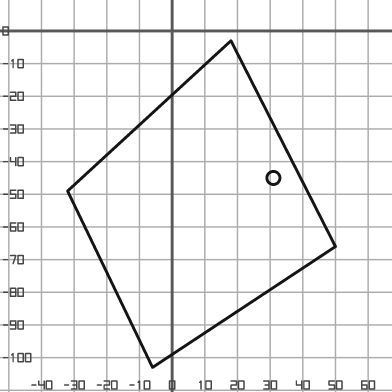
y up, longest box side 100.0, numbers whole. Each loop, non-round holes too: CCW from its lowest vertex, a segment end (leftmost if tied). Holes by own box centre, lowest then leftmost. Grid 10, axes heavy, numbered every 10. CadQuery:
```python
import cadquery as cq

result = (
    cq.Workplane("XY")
    .moveTo(-6.0, -103.0)
    .lineTo(50.0, -66.0)
    .lineTo(18.0, -3.0)
    .lineTo(-32.0, -49.0)
    .close()
    .moveTo(31.0, -45.0)
    .circle(2.0)
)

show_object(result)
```